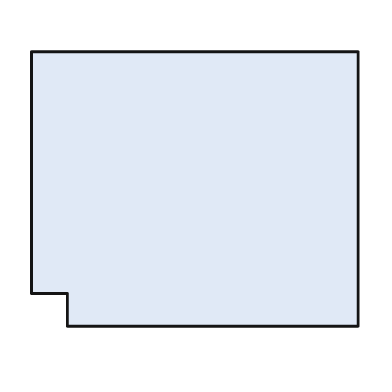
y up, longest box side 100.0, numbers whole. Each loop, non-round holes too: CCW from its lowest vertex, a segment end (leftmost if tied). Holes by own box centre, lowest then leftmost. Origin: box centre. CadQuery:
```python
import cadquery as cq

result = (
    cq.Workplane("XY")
    .moveTo(-39.0, -42.0)
    .lineTo(50.0, -42.0)
    .lineTo(50.0, 42.0)
    .lineTo(-50.0, 42.0)
    .lineTo(-50.0, -32.0)
    .lineTo(-39.0, -32.0)
    .close()
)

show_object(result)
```